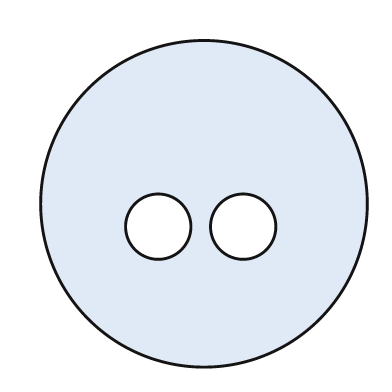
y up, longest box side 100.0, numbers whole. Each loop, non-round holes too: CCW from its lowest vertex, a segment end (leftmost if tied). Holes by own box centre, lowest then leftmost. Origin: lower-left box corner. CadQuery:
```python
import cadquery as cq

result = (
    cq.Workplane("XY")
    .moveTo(50.0, 50.0)
    .circle(50.0)
    .moveTo(36.0, 43.0)
    .circle(10.0)
    .moveTo(62.0, 43.0)
    .circle(10.0)
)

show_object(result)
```